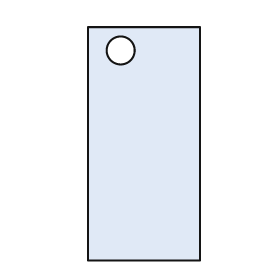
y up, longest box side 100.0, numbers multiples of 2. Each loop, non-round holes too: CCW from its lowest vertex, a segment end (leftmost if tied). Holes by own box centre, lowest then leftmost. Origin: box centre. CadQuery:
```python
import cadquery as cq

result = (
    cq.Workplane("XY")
    .moveTo(-24.0, -50.0)
    .lineTo(24.0, -50.0)
    .lineTo(24.0, 50.0)
    .lineTo(-24.0, 50.0)
    .close()
    .moveTo(-10.0, 40.0)
    .circle(6.0)
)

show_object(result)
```